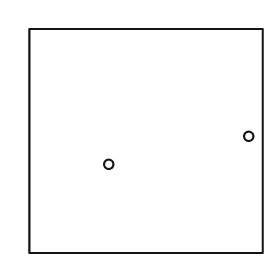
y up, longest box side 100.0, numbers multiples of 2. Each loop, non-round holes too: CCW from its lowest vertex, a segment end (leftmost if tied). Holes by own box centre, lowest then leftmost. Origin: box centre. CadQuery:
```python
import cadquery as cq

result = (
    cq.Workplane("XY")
    .moveTo(-50.0, -48.0)
    .lineTo(50.0, -48.0)
    .lineTo(50.0, 48.0)
    .lineTo(-50.0, 48.0)
    .close()
    .moveTo(-16.0, -10.0)
    .circle(2.0)
    .moveTo(44.0, 2.0)
    .circle(2.0)
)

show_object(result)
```